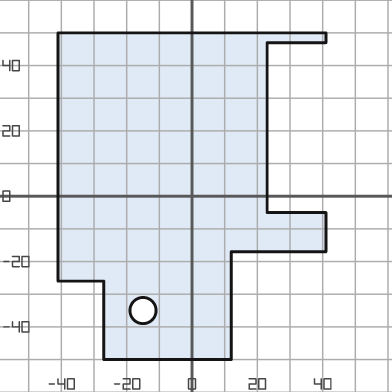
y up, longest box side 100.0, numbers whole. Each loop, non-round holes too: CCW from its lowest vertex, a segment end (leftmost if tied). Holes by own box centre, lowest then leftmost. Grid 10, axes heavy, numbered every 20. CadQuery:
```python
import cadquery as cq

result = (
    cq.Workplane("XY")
    .moveTo(-27.0, -50.0)
    .lineTo(12.0, -50.0)
    .lineTo(12.0, -17.0)
    .lineTo(41.0, -17.0)
    .lineTo(41.0, -5.0)
    .lineTo(23.0, -5.0)
    .lineTo(23.0, 47.0)
    .lineTo(41.0, 47.0)
    .lineTo(41.0, 50.0)
    .lineTo(-41.0, 50.0)
    .lineTo(-41.0, -26.0)
    .lineTo(-27.0, -26.0)
    .close()
    .moveTo(-15.0, -35.0)
    .circle(4.0)
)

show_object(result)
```